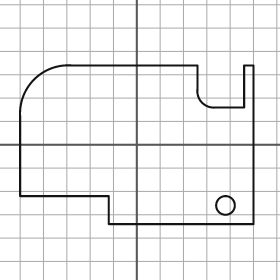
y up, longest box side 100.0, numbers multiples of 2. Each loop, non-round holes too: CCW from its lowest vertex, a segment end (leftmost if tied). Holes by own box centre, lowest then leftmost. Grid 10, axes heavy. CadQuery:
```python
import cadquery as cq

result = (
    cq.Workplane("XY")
    .moveTo(-12.0, -34.0)
    .lineTo(50.0, -34.0)
    .lineTo(50.0, 34.0)
    .lineTo(46.0, 34.0)
    .lineTo(46.0, 16.0)
    .lineTo(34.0, 16.0)
    .threePointArc((28.0, 18.0), (26.0, 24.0))
    .lineTo(26.0, 34.0)
    .lineTo(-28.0, 34.0)
    .threePointArc((-44.0, 28.0), (-50.0, 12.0))
    .lineTo(-50.0, -22.0)
    .lineTo(-12.0, -22.0)
    .close()
    .moveTo(38.0, -26.0)
    .circle(4.0)
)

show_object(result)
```